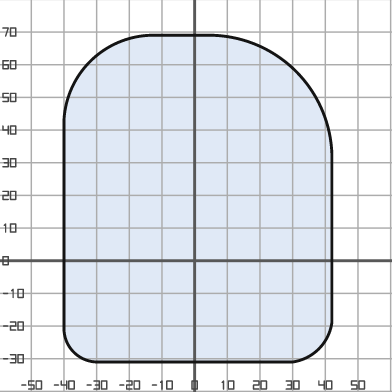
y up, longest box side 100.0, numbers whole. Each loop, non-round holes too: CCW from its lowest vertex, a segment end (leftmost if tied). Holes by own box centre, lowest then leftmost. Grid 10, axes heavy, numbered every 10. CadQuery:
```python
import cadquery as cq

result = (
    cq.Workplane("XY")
    .moveTo(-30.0, -31.0)
    .lineTo(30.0, -31.0)
    .threePointArc((38.0, -27.0), (42.0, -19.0))
    .lineTo(42.0, 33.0)
    .threePointArc((31.0, 58.0), (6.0, 69.0))
    .lineTo(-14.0, 69.0)
    .threePointArc((-32.0, 61.0), (-40.0, 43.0))
    .lineTo(-40.0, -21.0)
    .threePointArc((-37.0, -28.0), (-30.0, -31.0))
    .close()
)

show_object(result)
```